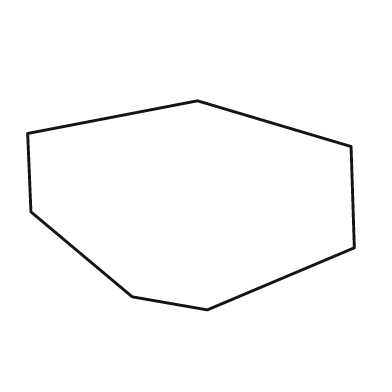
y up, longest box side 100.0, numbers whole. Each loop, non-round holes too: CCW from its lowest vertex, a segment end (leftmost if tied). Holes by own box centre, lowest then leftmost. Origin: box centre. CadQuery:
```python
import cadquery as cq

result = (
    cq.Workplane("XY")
    .moveTo(5.0, -32.0)
    .lineTo(50.0, -13.0)
    .lineTo(49.0, 18.0)
    .lineTo(2.0, 32.0)
    .lineTo(-50.0, 22.0)
    .lineTo(-49.0, -2.0)
    .lineTo(-18.0, -28.0)
    .close()
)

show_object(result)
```